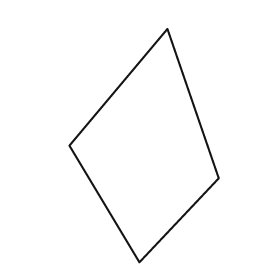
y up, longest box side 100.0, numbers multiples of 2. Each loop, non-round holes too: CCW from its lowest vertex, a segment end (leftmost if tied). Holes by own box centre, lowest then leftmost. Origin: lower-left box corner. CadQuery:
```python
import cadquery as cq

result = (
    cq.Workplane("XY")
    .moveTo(30.0, 0.0)
    .lineTo(64.0, 36.0)
    .lineTo(42.0, 100.0)
    .lineTo(0.0, 50.0)
    .close()
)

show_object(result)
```